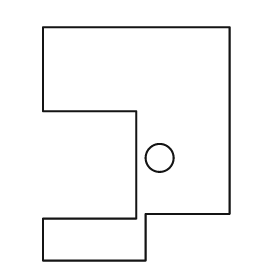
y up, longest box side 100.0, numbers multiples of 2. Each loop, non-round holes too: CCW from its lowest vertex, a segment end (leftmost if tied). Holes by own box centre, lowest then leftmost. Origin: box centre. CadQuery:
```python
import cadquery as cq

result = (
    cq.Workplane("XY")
    .moveTo(-40.0, -50.0)
    .lineTo(4.0, -50.0)
    .lineTo(4.0, -30.0)
    .lineTo(40.0, -30.0)
    .lineTo(40.0, 50.0)
    .lineTo(-40.0, 50.0)
    .lineTo(-40.0, 14.0)
    .lineTo(0.0, 14.0)
    .lineTo(0.0, -32.0)
    .lineTo(-40.0, -32.0)
    .close()
    .moveTo(10.0, -6.0)
    .circle(6.0)
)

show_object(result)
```